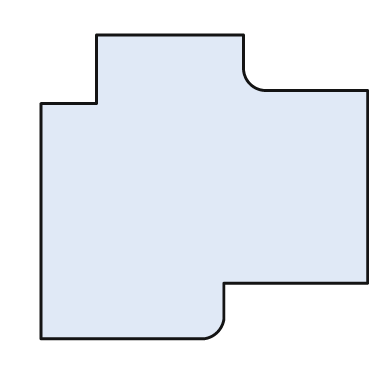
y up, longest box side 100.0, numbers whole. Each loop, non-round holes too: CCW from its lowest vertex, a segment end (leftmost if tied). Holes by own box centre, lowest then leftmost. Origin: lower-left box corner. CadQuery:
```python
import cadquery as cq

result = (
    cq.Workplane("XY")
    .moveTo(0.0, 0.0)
    .lineTo(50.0, 0.0)
    .threePointArc((54.0, 2.0), (56.0, 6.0))
    .lineTo(56.0, 17.0)
    .lineTo(100.0, 17.0)
    .lineTo(100.0, 76.0)
    .lineTo(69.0, 76.0)
    .threePointArc((64.0, 78.0), (62.0, 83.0))
    .lineTo(62.0, 93.0)
    .lineTo(17.0, 93.0)
    .lineTo(17.0, 72.0)
    .lineTo(0.0, 72.0)
    .close()
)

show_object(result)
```